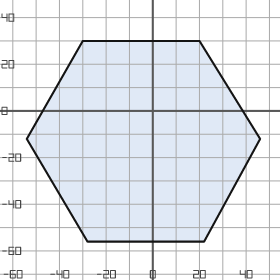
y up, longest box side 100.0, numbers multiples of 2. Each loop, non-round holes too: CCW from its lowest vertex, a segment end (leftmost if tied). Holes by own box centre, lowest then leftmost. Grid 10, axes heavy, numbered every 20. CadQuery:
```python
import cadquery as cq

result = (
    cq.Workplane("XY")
    .moveTo(-28.0, -56.0)
    .lineTo(22.0, -56.0)
    .lineTo(46.0, -12.0)
    .lineTo(20.0, 30.0)
    .lineTo(-30.0, 30.0)
    .lineTo(-54.0, -12.0)
    .close()
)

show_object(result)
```